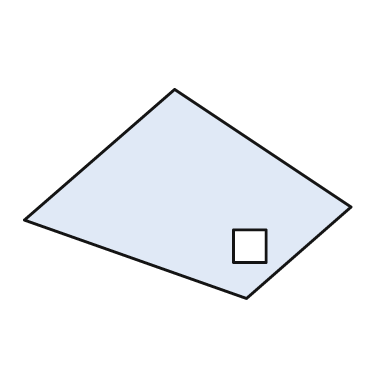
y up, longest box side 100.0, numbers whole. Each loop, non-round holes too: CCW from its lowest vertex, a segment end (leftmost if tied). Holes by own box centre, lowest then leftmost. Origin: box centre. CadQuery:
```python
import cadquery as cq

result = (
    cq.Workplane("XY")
    .moveTo(18.0, -32.0)
    .lineTo(50.0, -4.0)
    .lineTo(-4.0, 32.0)
    .lineTo(-50.0, -8.0)
    .close()
    .moveTo(14.0, -21.0)
    .lineTo(24.0, -21.0)
    .lineTo(24.0, -11.0)
    .lineTo(14.0, -11.0)
    .close()
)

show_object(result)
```